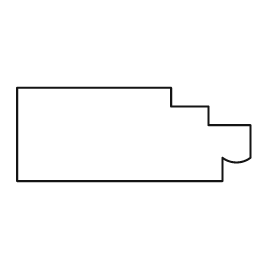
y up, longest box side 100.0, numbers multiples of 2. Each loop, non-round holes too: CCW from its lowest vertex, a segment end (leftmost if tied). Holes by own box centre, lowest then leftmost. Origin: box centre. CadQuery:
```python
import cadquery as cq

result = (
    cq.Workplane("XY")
    .moveTo(-50.0, -20.0)
    .lineTo(38.0, -20.0)
    .lineTo(38.0, -10.0)
    .threePointArc((44.0, -12.0), (50.0, -10.0))
    .lineTo(50.0, 4.0)
    .lineTo(32.0, 4.0)
    .lineTo(32.0, 12.0)
    .lineTo(16.0, 12.0)
    .lineTo(16.0, 20.0)
    .lineTo(-50.0, 20.0)
    .close()
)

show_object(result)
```